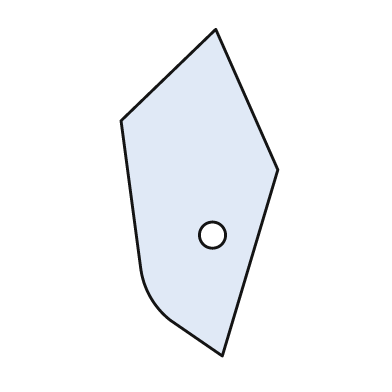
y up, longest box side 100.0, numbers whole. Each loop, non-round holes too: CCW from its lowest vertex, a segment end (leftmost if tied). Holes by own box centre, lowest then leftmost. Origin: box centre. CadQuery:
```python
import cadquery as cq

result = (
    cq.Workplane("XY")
    .moveTo(7.0, -50.0)
    .lineTo(24.0, 7.0)
    .lineTo(5.0, 50.0)
    .lineTo(-24.0, 22.0)
    .lineTo(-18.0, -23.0)
    .threePointArc((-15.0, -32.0), (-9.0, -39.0))
    .close()
    .moveTo(4.0, -13.0)
    .circle(4.0)
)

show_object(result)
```